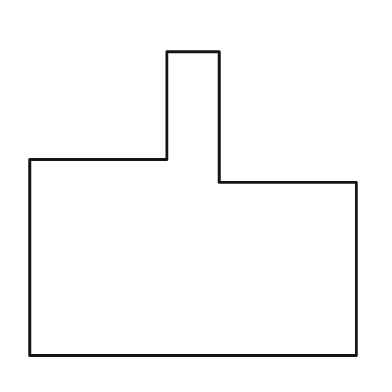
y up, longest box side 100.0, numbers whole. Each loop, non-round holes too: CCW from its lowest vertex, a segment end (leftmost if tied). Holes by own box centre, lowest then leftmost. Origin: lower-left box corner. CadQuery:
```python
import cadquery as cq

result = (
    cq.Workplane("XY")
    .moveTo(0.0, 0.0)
    .lineTo(100.0, 0.0)
    .lineTo(100.0, 53.0)
    .lineTo(58.0, 53.0)
    .lineTo(58.0, 93.0)
    .lineTo(42.0, 93.0)
    .lineTo(42.0, 60.0)
    .lineTo(0.0, 60.0)
    .close()
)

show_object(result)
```